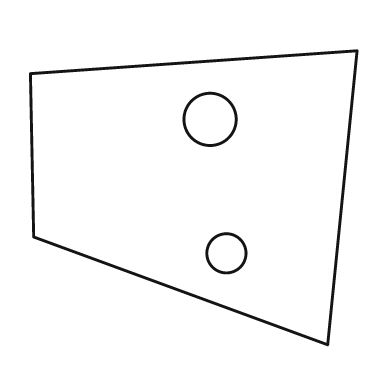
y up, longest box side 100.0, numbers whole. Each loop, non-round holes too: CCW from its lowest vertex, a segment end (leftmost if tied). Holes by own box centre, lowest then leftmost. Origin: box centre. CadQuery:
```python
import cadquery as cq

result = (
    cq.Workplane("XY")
    .moveTo(41.0, -45.0)
    .lineTo(50.0, 45.0)
    .lineTo(-50.0, 38.0)
    .lineTo(-49.0, -12.0)
    .close()
    .moveTo(10.0, -17.0)
    .circle(6.0)
    .moveTo(5.0, 24.0)
    .circle(8.0)
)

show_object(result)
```